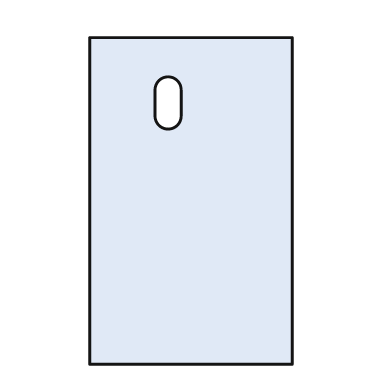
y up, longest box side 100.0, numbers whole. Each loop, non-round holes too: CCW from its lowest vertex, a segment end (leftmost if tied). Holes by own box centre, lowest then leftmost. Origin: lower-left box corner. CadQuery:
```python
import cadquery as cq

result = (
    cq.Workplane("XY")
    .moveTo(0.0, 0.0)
    .lineTo(62.0, 0.0)
    .lineTo(62.0, 100.0)
    .lineTo(0.0, 100.0)
    .close()
    .moveTo(20.0, 76.0)
    .threePointArc((24.0, 72.0), (28.0, 76.0))
    .lineTo(28.0, 84.0)
    .threePointArc((24.0, 88.0), (20.0, 84.0))
    .close()
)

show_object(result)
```